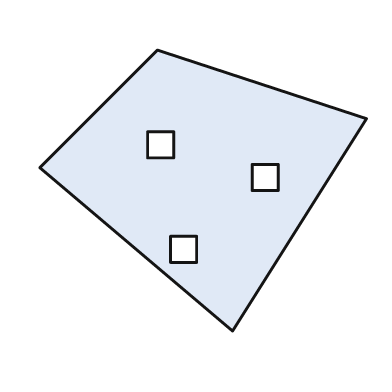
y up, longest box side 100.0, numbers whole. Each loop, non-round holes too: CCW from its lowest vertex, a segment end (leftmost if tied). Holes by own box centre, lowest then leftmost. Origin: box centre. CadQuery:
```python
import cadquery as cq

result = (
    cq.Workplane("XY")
    .moveTo(9.0, -43.0)
    .lineTo(50.0, 22.0)
    .lineTo(-14.0, 43.0)
    .lineTo(-50.0, 7.0)
    .close()
    .moveTo(-10.0, -22.0)
    .lineTo(-2.0, -22.0)
    .lineTo(-2.0, -14.0)
    .lineTo(-10.0, -14.0)
    .close()
    .moveTo(15.0, 0.0)
    .lineTo(23.0, 0.0)
    .lineTo(23.0, 8.0)
    .lineTo(15.0, 8.0)
    .close()
    .moveTo(-17.0, 10.0)
    .lineTo(-9.0, 10.0)
    .lineTo(-9.0, 18.0)
    .lineTo(-17.0, 18.0)
    .close()
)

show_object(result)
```